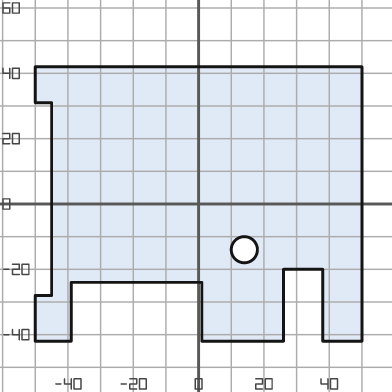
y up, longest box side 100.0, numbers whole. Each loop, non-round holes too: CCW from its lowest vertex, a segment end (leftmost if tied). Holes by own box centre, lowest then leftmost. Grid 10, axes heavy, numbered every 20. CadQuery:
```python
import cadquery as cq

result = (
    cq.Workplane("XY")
    .moveTo(-50.0, -42.0)
    .lineTo(-39.0, -42.0)
    .lineTo(-39.0, -24.0)
    .lineTo(1.0, -24.0)
    .lineTo(1.0, -42.0)
    .lineTo(26.0, -42.0)
    .lineTo(26.0, -20.0)
    .lineTo(38.0, -20.0)
    .lineTo(38.0, -42.0)
    .lineTo(50.0, -42.0)
    .lineTo(50.0, 42.0)
    .lineTo(-50.0, 42.0)
    .lineTo(-50.0, 31.0)
    .lineTo(-45.0, 31.0)
    .lineTo(-45.0, -28.0)
    .lineTo(-50.0, -28.0)
    .close()
    .moveTo(14.0, -14.0)
    .circle(4.0)
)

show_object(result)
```